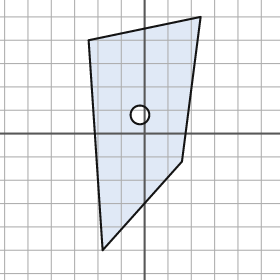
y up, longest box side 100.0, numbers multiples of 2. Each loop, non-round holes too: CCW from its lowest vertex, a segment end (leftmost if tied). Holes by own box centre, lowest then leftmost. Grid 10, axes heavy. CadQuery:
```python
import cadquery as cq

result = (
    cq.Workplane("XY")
    .moveTo(-18.0, -50.0)
    .lineTo(16.0, -12.0)
    .lineTo(24.0, 50.0)
    .lineTo(-24.0, 40.0)
    .close()
    .moveTo(-2.0, 8.0)
    .circle(4.0)
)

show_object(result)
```